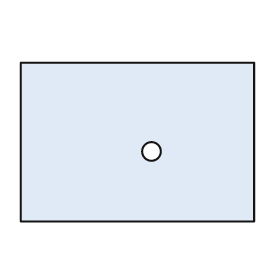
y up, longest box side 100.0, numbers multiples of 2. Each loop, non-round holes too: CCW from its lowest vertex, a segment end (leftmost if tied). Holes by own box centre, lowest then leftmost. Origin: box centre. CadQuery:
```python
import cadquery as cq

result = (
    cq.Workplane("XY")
    .moveTo(-50.0, -34.0)
    .lineTo(50.0, -34.0)
    .lineTo(50.0, 34.0)
    .lineTo(-50.0, 34.0)
    .close()
    .moveTo(6.0, -4.0)
    .circle(4.0)
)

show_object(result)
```